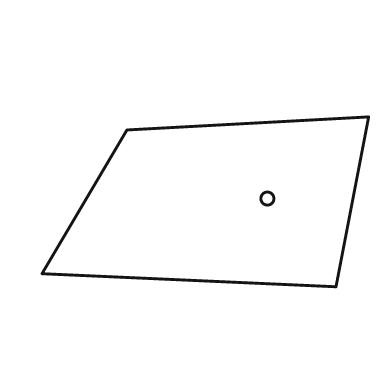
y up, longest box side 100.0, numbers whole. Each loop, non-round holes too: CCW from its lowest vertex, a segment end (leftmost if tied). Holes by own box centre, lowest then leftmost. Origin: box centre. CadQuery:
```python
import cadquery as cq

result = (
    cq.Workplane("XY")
    .moveTo(40.0, -26.0)
    .lineTo(50.0, 26.0)
    .lineTo(-24.0, 22.0)
    .lineTo(-50.0, -22.0)
    .close()
    .moveTo(19.0, 1.0)
    .circle(2.0)
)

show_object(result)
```